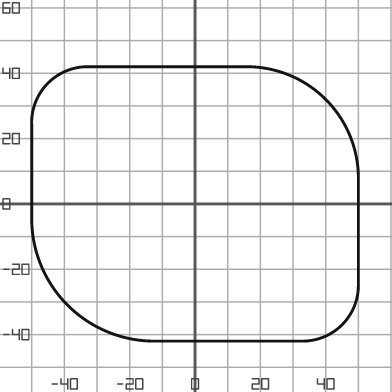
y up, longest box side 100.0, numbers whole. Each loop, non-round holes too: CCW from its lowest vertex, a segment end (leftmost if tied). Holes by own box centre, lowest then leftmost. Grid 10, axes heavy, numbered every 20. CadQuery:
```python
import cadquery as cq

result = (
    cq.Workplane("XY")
    .moveTo(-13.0, -42.0)
    .lineTo(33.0, -42.0)
    .threePointArc((45.0, -37.0), (50.0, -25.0))
    .lineTo(50.0, 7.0)
    .threePointArc((40.0, 32.0), (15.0, 42.0))
    .lineTo(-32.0, 42.0)
    .threePointArc((-45.0, 37.0), (-50.0, 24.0))
    .lineTo(-50.0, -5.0)
    .threePointArc((-39.0, -31.0), (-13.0, -42.0))
    .close()
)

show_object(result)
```